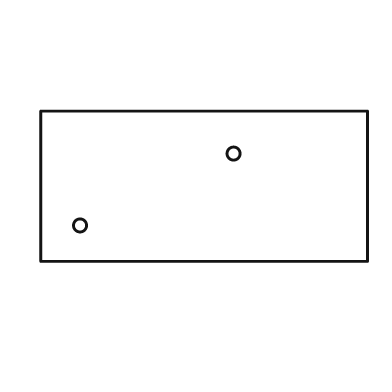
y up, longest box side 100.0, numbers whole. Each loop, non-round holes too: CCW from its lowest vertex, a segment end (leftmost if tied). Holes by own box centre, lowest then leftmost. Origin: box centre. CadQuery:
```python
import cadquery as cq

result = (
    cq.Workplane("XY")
    .moveTo(-50.0, -23.0)
    .lineTo(50.0, -23.0)
    .lineTo(50.0, 23.0)
    .lineTo(-50.0, 23.0)
    .close()
    .moveTo(-38.0, -12.0)
    .circle(2.0)
    .moveTo(9.0, 10.0)
    .circle(2.0)
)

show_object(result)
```